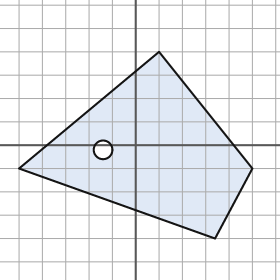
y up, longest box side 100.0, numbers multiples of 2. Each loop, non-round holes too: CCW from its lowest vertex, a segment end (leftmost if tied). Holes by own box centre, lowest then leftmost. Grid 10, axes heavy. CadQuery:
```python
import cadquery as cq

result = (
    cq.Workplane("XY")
    .moveTo(34.0, -40.0)
    .lineTo(50.0, -10.0)
    .lineTo(10.0, 40.0)
    .lineTo(-50.0, -10.0)
    .close()
    .moveTo(-14.0, -2.0)
    .circle(4.0)
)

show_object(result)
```